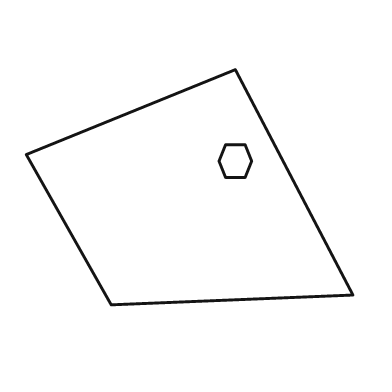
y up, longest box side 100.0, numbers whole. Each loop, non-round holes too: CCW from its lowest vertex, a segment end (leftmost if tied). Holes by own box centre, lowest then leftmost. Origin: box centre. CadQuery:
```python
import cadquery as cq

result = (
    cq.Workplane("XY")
    .moveTo(-24.0, -36.0)
    .lineTo(50.0, -33.0)
    .lineTo(14.0, 36.0)
    .lineTo(-50.0, 10.0)
    .close()
    .moveTo(11.0, 3.0)
    .lineTo(17.0, 3.0)
    .lineTo(19.0, 8.0)
    .lineTo(17.0, 13.0)
    .lineTo(11.0, 13.0)
    .lineTo(9.0, 8.0)
    .close()
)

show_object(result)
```